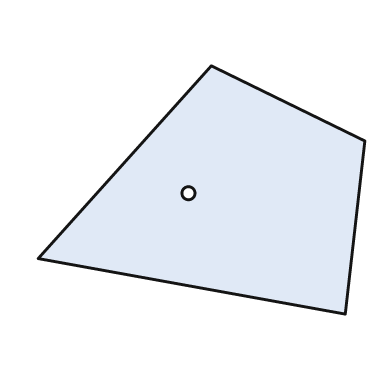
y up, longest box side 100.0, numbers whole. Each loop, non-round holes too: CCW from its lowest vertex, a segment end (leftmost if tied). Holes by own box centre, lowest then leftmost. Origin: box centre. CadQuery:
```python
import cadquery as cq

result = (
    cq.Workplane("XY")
    .moveTo(44.0, -38.0)
    .lineTo(50.0, 15.0)
    .lineTo(3.0, 38.0)
    .lineTo(-50.0, -21.0)
    .close()
    .moveTo(-4.0, -1.0)
    .circle(2.0)
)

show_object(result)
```